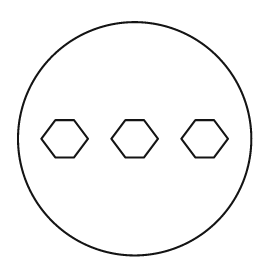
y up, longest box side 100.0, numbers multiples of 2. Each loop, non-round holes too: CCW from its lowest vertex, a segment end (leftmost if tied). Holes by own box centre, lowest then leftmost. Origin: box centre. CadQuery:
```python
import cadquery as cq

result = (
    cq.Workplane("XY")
    .moveTo(0.0, 0.0)
    .circle(50.0)
    .moveTo(-34.0, -8.0)
    .lineTo(-26.0, -8.0)
    .lineTo(-20.0, 0.0)
    .lineTo(-26.0, 8.0)
    .lineTo(-34.0, 8.0)
    .lineTo(-40.0, 0.0)
    .close()
    .moveTo(-4.0, -8.0)
    .lineTo(4.0, -8.0)
    .lineTo(10.0, 0.0)
    .lineTo(4.0, 8.0)
    .lineTo(-4.0, 8.0)
    .lineTo(-10.0, 0.0)
    .close()
    .moveTo(26.0, -8.0)
    .lineTo(34.0, -8.0)
    .lineTo(40.0, 0.0)
    .lineTo(34.0, 8.0)
    .lineTo(26.0, 8.0)
    .lineTo(20.0, 0.0)
    .close()
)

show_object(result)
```